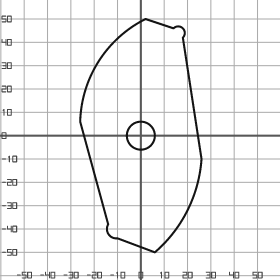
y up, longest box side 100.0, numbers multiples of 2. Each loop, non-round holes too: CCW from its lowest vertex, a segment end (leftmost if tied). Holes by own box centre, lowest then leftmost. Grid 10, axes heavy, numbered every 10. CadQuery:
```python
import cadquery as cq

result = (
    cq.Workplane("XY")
    .moveTo(6.0, -50.0)
    .threePointArc((20.0, -32.0), (26.0, -10.0))
    .lineTo(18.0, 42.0)
    .threePointArc((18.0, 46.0), (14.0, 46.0))
    .lineTo(2.0, 50.0)
    .threePointArc((-18.0, 32.0), (-26.0, 6.0))
    .lineTo(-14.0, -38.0)
    .threePointArc((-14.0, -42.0), (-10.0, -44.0))
    .close()
    .moveTo(0.0, 0.0)
    .circle(6.0)
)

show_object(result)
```